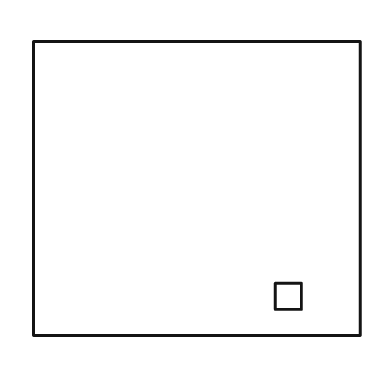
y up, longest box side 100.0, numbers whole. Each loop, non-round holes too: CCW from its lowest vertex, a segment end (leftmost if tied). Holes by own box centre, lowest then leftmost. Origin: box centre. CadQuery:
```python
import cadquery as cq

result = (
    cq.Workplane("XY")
    .moveTo(-50.0, -45.0)
    .lineTo(50.0, -45.0)
    .lineTo(50.0, 45.0)
    .lineTo(-50.0, 45.0)
    .close()
    .moveTo(24.0, -37.0)
    .lineTo(32.0, -37.0)
    .lineTo(32.0, -29.0)
    .lineTo(24.0, -29.0)
    .close()
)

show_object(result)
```